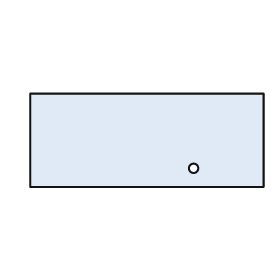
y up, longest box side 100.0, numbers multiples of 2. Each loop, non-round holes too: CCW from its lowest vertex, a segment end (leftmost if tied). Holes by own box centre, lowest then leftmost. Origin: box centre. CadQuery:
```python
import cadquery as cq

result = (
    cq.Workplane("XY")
    .moveTo(-50.0, -20.0)
    .lineTo(50.0, -20.0)
    .lineTo(50.0, 20.0)
    .lineTo(-50.0, 20.0)
    .close()
    .moveTo(20.0, -12.0)
    .circle(2.0)
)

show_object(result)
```